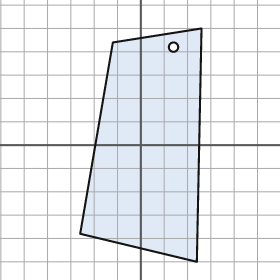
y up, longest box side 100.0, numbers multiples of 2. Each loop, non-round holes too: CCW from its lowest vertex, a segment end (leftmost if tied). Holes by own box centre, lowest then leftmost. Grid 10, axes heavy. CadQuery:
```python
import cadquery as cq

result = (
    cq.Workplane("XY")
    .moveTo(24.0, -50.0)
    .lineTo(26.0, 50.0)
    .lineTo(-12.0, 44.0)
    .lineTo(-26.0, -38.0)
    .close()
    .moveTo(14.0, 42.0)
    .circle(2.0)
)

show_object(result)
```